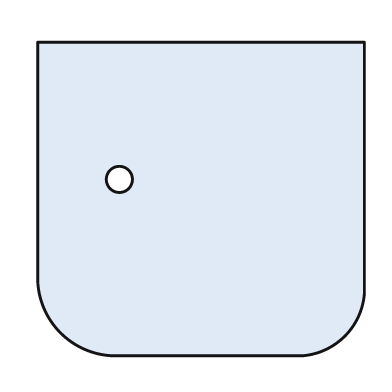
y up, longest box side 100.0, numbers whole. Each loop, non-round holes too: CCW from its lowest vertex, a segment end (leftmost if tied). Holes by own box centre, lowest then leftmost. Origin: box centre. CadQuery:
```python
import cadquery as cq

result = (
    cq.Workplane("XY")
    .moveTo(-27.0, -48.0)
    .lineTo(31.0, -48.0)
    .threePointArc((44.0, -42.0), (50.0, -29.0))
    .lineTo(50.0, 48.0)
    .lineTo(-50.0, 48.0)
    .lineTo(-50.0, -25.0)
    .threePointArc((-43.0, -41.0), (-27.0, -48.0))
    .close()
    .moveTo(-25.0, 6.0)
    .circle(4.0)
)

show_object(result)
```